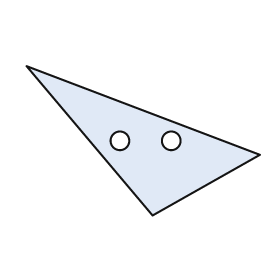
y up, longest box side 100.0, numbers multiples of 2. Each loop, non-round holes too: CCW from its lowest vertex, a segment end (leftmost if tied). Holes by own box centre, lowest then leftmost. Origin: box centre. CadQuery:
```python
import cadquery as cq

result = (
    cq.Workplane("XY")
    .moveTo(4.0, -32.0)
    .lineTo(50.0, -6.0)
    .lineTo(-50.0, 32.0)
    .close()
    .moveTo(-10.0, 0.0)
    .circle(4.0)
    .moveTo(12.0, 0.0)
    .circle(4.0)
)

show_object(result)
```